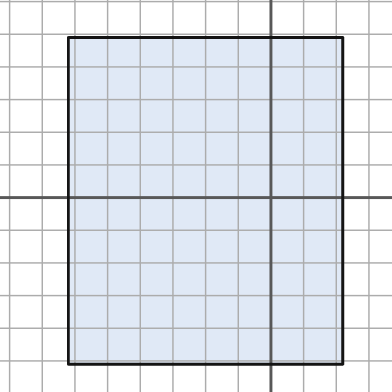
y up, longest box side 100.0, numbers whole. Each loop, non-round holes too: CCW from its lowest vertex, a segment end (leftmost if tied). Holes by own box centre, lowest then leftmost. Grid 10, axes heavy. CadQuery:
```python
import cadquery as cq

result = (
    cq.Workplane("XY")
    .moveTo(-62.0, -51.0)
    .lineTo(22.0, -51.0)
    .lineTo(22.0, 49.0)
    .lineTo(-62.0, 49.0)
    .close()
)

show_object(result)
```